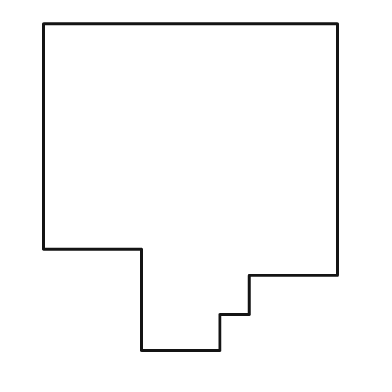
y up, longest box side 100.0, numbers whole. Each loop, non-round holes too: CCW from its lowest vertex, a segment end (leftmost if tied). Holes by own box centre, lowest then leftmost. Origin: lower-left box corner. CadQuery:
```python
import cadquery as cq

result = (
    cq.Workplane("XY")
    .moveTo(30.0, 0.0)
    .lineTo(54.0, 0.0)
    .lineTo(54.0, 11.0)
    .lineTo(63.0, 11.0)
    .lineTo(63.0, 23.0)
    .lineTo(90.0, 23.0)
    .lineTo(90.0, 100.0)
    .lineTo(0.0, 100.0)
    .lineTo(0.0, 31.0)
    .lineTo(30.0, 31.0)
    .close()
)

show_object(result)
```